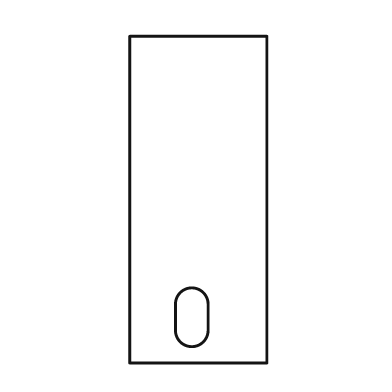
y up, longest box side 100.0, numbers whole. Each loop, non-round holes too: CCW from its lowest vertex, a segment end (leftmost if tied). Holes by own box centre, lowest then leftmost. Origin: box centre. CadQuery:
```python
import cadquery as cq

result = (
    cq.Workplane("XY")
    .moveTo(-21.0, -50.0)
    .lineTo(21.0, -50.0)
    .lineTo(21.0, 50.0)
    .lineTo(-21.0, 50.0)
    .close()
    .moveTo(-7.0, -40.0)
    .threePointArc((-2.0, -45.0), (3.0, -40.0))
    .lineTo(3.0, -32.0)
    .threePointArc((-2.0, -27.0), (-7.0, -32.0))
    .close()
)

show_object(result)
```